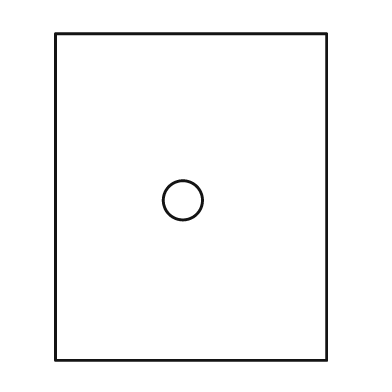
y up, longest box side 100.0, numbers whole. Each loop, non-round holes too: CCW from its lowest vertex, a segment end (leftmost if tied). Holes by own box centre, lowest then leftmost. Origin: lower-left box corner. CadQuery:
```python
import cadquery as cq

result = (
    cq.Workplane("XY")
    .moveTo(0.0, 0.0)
    .lineTo(83.0, 0.0)
    .lineTo(83.0, 100.0)
    .lineTo(0.0, 100.0)
    .close()
    .moveTo(39.0, 49.0)
    .circle(6.0)
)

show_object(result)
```